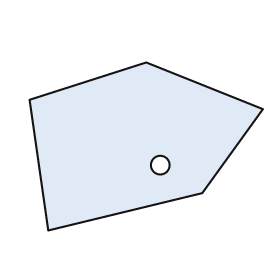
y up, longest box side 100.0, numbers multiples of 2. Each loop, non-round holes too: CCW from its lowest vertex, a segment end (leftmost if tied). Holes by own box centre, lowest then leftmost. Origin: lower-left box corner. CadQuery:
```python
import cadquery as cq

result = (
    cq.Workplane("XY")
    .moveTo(8.0, 0.0)
    .lineTo(74.0, 16.0)
    .lineTo(100.0, 52.0)
    .lineTo(50.0, 72.0)
    .lineTo(0.0, 56.0)
    .close()
    .moveTo(56.0, 28.0)
    .circle(4.0)
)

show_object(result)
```